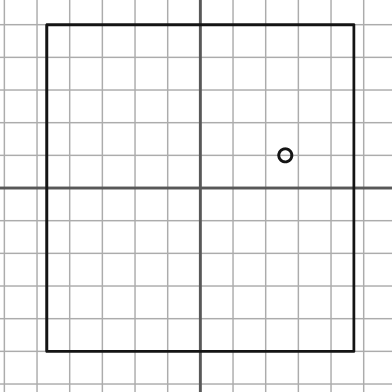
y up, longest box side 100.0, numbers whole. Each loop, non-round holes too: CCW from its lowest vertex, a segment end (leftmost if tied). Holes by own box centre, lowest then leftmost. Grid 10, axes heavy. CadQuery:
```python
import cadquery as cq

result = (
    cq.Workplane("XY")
    .moveTo(-47.0, -50.0)
    .lineTo(47.0, -50.0)
    .lineTo(47.0, 50.0)
    .lineTo(-47.0, 50.0)
    .close()
    .moveTo(26.0, 10.0)
    .circle(2.0)
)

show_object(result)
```